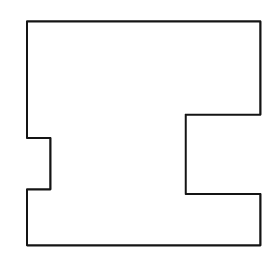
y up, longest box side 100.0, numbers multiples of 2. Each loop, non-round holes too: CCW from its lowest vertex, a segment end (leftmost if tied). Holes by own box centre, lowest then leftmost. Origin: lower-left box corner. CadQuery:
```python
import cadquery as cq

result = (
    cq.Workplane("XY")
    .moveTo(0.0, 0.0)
    .lineTo(100.0, 0.0)
    .lineTo(100.0, 22.0)
    .lineTo(68.0, 22.0)
    .lineTo(68.0, 56.0)
    .lineTo(100.0, 56.0)
    .lineTo(100.0, 96.0)
    .lineTo(0.0, 96.0)
    .lineTo(0.0, 46.0)
    .lineTo(10.0, 46.0)
    .lineTo(10.0, 24.0)
    .lineTo(0.0, 24.0)
    .close()
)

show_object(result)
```